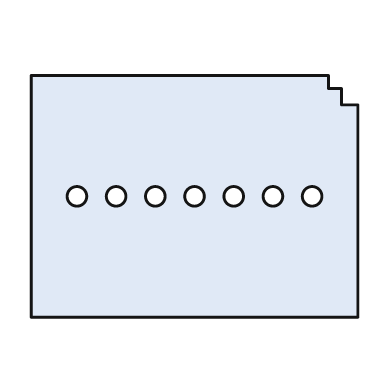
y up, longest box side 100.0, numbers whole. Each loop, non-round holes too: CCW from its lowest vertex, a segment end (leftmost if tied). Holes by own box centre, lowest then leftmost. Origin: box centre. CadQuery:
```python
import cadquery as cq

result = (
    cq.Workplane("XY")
    .moveTo(-50.0, -37.0)
    .lineTo(50.0, -37.0)
    .lineTo(50.0, 28.0)
    .lineTo(45.0, 28.0)
    .lineTo(45.0, 33.0)
    .lineTo(41.0, 33.0)
    .lineTo(41.0, 37.0)
    .lineTo(-50.0, 37.0)
    .close()
    .moveTo(-36.0, 0.0)
    .circle(3.0)
    .moveTo(-24.0, 0.0)
    .circle(3.0)
    .moveTo(-12.0, 0.0)
    .circle(3.0)
    .moveTo(0.0, 0.0)
    .circle(3.0)
    .moveTo(12.0, 0.0)
    .circle(3.0)
    .moveTo(24.0, 0.0)
    .circle(3.0)
    .moveTo(36.0, 0.0)
    .circle(3.0)
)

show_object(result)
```